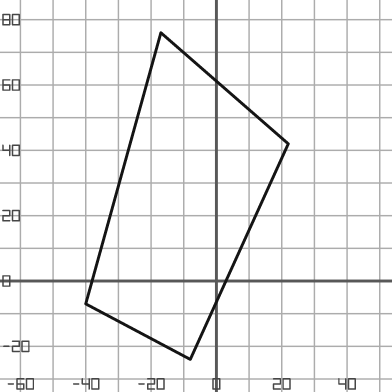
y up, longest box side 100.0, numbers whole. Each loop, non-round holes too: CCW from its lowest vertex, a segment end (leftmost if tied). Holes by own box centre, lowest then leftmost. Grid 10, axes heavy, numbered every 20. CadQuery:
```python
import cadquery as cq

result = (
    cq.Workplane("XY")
    .moveTo(-8.0, -24.0)
    .lineTo(22.0, 42.0)
    .lineTo(-17.0, 76.0)
    .lineTo(-40.0, -7.0)
    .close()
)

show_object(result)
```